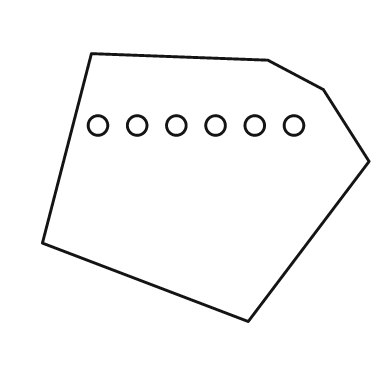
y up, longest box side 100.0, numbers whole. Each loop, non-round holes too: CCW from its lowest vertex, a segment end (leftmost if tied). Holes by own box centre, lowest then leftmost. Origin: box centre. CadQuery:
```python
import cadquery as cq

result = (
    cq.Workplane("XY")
    .moveTo(13.0, -41.0)
    .lineTo(50.0, 8.0)
    .lineTo(36.0, 30.0)
    .lineTo(19.0, 39.0)
    .lineTo(-35.0, 41.0)
    .lineTo(-50.0, -17.0)
    .close()
    .moveTo(-33.0, 19.0)
    .circle(3.0)
    .moveTo(-21.0, 19.0)
    .circle(3.0)
    .moveTo(-9.0, 19.0)
    .circle(3.0)
    .moveTo(3.0, 19.0)
    .circle(3.0)
    .moveTo(15.0, 19.0)
    .circle(3.0)
    .moveTo(27.0, 19.0)
    .circle(3.0)
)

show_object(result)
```